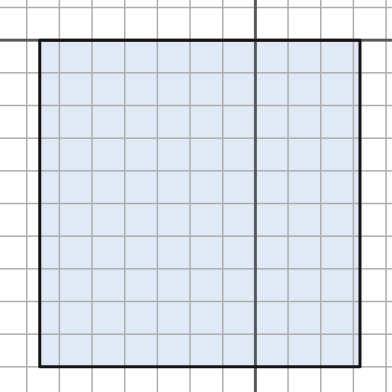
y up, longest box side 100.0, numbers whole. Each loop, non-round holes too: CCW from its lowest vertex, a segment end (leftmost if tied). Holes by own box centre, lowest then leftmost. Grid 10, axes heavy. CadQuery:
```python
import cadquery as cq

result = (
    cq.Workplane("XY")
    .moveTo(-66.0, -100.0)
    .lineTo(32.0, -100.0)
    .lineTo(32.0, 0.0)
    .lineTo(-66.0, 0.0)
    .close()
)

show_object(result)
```